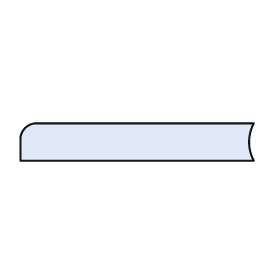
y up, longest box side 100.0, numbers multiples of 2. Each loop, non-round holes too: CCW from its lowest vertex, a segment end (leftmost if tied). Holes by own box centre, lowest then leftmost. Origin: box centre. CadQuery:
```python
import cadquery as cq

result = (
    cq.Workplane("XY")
    .moveTo(-50.0, -8.0)
    .lineTo(50.0, -8.0)
    .threePointArc((48.0, 0.0), (50.0, 8.0))
    .lineTo(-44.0, 8.0)
    .threePointArc((-48.0, 6.0), (-50.0, 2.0))
    .close()
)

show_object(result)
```